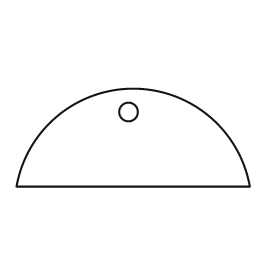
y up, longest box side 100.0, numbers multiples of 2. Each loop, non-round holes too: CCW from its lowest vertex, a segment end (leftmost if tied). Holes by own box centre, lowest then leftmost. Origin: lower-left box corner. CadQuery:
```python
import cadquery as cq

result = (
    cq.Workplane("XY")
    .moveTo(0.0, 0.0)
    .lineTo(100.0, 0.0)
    .threePointArc((50.0, 42.0), (0.0, 0.0))
    .close()
    .moveTo(48.0, 32.0)
    .circle(4.0)
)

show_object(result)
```